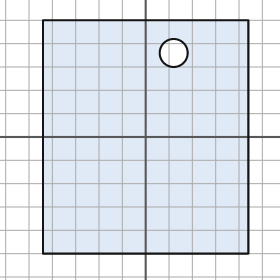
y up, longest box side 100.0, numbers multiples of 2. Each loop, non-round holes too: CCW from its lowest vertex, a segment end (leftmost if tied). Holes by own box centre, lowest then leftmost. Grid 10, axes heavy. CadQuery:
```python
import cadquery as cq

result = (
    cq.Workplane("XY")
    .moveTo(-44.0, -50.0)
    .lineTo(44.0, -50.0)
    .lineTo(44.0, 50.0)
    .lineTo(-44.0, 50.0)
    .close()
    .moveTo(12.0, 36.0)
    .circle(6.0)
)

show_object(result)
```